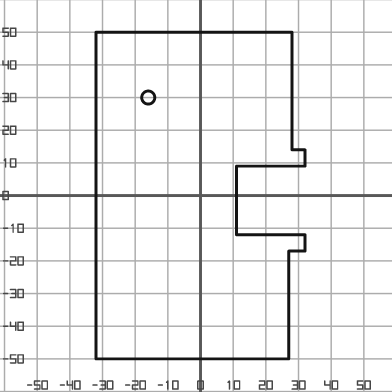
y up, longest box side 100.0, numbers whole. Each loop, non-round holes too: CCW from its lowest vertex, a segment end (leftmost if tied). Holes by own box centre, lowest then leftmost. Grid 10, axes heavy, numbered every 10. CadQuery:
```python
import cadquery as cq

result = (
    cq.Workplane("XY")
    .moveTo(-32.0, -50.0)
    .lineTo(27.0, -50.0)
    .lineTo(27.0, -17.0)
    .lineTo(32.0, -17.0)
    .lineTo(32.0, -12.0)
    .lineTo(11.0, -12.0)
    .lineTo(11.0, 9.0)
    .lineTo(32.0, 9.0)
    .lineTo(32.0, 14.0)
    .lineTo(28.0, 14.0)
    .lineTo(28.0, 50.0)
    .lineTo(-32.0, 50.0)
    .close()
    .moveTo(-16.0, 30.0)
    .circle(2.0)
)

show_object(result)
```